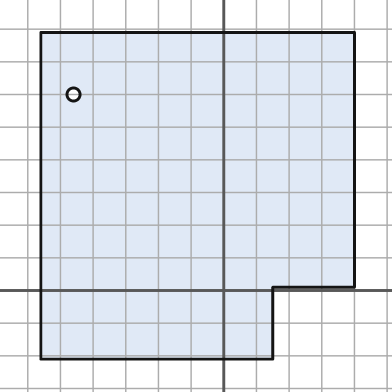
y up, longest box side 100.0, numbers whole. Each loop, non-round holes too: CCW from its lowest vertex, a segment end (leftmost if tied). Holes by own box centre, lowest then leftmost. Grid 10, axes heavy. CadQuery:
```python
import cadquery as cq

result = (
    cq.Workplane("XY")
    .moveTo(-56.0, -21.0)
    .lineTo(15.0, -21.0)
    .lineTo(15.0, 1.0)
    .lineTo(40.0, 1.0)
    .lineTo(40.0, 79.0)
    .lineTo(-56.0, 79.0)
    .close()
    .moveTo(-46.0, 60.0)
    .circle(2.0)
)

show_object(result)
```